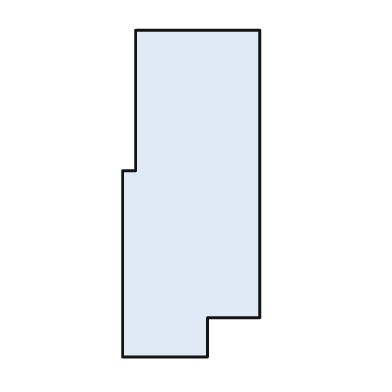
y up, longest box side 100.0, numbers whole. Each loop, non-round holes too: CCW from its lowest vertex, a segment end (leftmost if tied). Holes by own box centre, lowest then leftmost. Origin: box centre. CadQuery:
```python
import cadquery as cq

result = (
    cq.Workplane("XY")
    .moveTo(-21.0, -50.0)
    .lineTo(5.0, -50.0)
    .lineTo(5.0, -38.0)
    .lineTo(21.0, -38.0)
    .lineTo(21.0, 50.0)
    .lineTo(-17.0, 50.0)
    .lineTo(-17.0, 7.0)
    .lineTo(-21.0, 7.0)
    .close()
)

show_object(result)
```